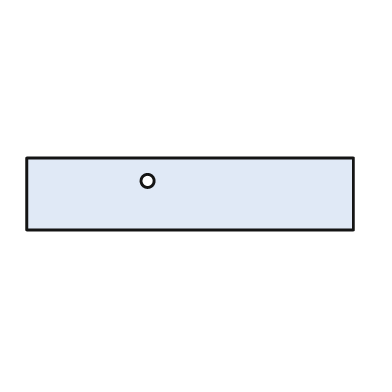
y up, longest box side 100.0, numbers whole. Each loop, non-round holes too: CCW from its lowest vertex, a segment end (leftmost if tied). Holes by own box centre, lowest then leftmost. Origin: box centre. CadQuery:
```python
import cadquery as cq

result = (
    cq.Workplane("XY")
    .moveTo(-50.0, -11.0)
    .lineTo(50.0, -11.0)
    .lineTo(50.0, 11.0)
    .lineTo(-50.0, 11.0)
    .close()
    .moveTo(-13.0, 4.0)
    .circle(2.0)
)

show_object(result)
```